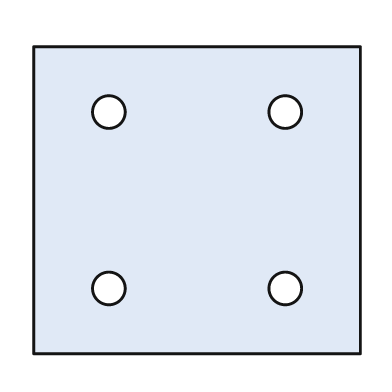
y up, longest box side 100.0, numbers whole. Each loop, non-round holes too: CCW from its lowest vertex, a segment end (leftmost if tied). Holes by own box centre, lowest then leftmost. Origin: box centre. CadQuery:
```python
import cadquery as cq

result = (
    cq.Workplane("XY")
    .moveTo(-50.0, -47.0)
    .lineTo(50.0, -47.0)
    .lineTo(50.0, 47.0)
    .lineTo(-50.0, 47.0)
    .close()
    .moveTo(-27.0, -27.0)
    .circle(5.0)
    .moveTo(27.0, -27.0)
    .circle(5.0)
    .moveTo(-27.0, 27.0)
    .circle(5.0)
    .moveTo(27.0, 27.0)
    .circle(5.0)
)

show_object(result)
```